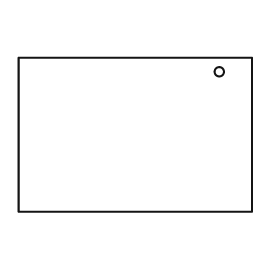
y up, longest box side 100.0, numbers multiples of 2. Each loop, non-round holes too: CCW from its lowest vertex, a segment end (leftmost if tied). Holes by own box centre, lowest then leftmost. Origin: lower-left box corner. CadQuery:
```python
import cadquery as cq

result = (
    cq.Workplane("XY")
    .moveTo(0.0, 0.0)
    .lineTo(100.0, 0.0)
    .lineTo(100.0, 66.0)
    .lineTo(0.0, 66.0)
    .close()
    .moveTo(86.0, 60.0)
    .circle(2.0)
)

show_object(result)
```